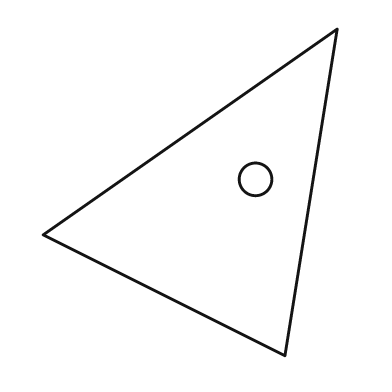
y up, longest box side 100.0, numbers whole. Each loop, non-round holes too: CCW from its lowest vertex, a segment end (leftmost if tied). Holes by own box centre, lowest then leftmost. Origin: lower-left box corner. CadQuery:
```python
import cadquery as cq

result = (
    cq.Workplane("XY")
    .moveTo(74.0, 0.0)
    .lineTo(90.0, 100.0)
    .lineTo(0.0, 37.0)
    .close()
    .moveTo(65.0, 54.0)
    .circle(5.0)
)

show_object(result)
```